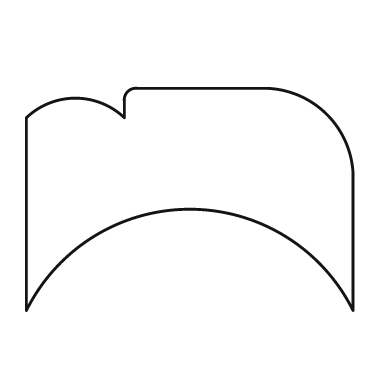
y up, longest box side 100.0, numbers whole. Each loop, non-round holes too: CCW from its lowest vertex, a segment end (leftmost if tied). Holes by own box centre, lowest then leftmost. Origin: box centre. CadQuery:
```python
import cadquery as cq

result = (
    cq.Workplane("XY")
    .moveTo(-50.0, -34.0)
    .threePointArc((0.0, -3.0), (50.0, -34.0))
    .lineTo(50.0, 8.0)
    .threePointArc((42.0, 26.0), (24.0, 34.0))
    .lineTo(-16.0, 34.0)
    .threePointArc((-19.0, 33.0), (-20.0, 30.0))
    .lineTo(-20.0, 25.0)
    .threePointArc((-35.0, 31.0), (-50.0, 25.0))
    .close()
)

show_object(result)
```